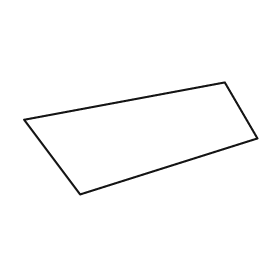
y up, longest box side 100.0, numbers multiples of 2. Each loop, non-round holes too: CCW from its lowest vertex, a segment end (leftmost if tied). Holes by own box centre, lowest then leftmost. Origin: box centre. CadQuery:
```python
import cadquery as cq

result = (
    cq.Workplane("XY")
    .moveTo(-26.0, -24.0)
    .lineTo(50.0, 0.0)
    .lineTo(36.0, 24.0)
    .lineTo(-50.0, 8.0)
    .close()
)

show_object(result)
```